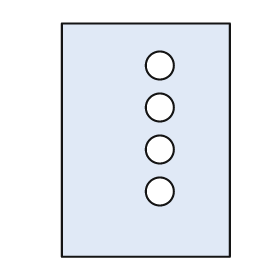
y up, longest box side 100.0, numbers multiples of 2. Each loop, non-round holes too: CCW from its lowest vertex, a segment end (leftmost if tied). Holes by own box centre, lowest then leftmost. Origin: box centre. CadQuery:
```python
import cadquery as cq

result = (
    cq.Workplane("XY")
    .moveTo(-36.0, -50.0)
    .lineTo(36.0, -50.0)
    .lineTo(36.0, 50.0)
    .lineTo(-36.0, 50.0)
    .close()
    .moveTo(6.0, -22.0)
    .circle(6.0)
    .moveTo(6.0, -4.0)
    .circle(6.0)
    .moveTo(6.0, 14.0)
    .circle(6.0)
    .moveTo(6.0, 32.0)
    .circle(6.0)
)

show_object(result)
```